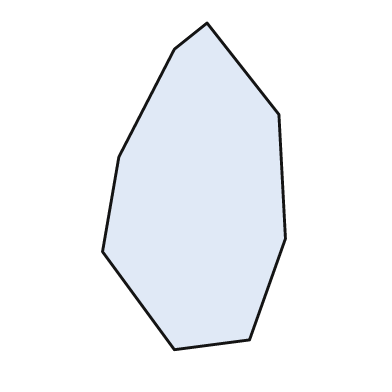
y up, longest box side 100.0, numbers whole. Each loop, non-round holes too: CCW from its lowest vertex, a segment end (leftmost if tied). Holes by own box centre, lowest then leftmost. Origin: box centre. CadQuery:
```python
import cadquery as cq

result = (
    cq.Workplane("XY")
    .moveTo(-6.0, -50.0)
    .lineTo(17.0, -47.0)
    .lineTo(28.0, -16.0)
    .lineTo(26.0, 22.0)
    .lineTo(4.0, 50.0)
    .lineTo(-6.0, 42.0)
    .lineTo(-23.0, 9.0)
    .lineTo(-28.0, -20.0)
    .close()
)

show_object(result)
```